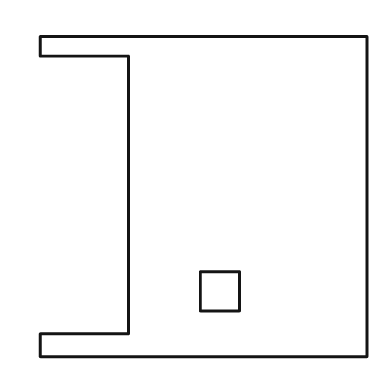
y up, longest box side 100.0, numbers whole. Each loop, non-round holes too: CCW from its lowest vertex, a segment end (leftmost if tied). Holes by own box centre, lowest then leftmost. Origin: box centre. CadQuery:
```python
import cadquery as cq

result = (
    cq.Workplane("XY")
    .moveTo(-50.0, -49.0)
    .lineTo(50.0, -49.0)
    .lineTo(50.0, 49.0)
    .lineTo(-50.0, 49.0)
    .lineTo(-50.0, 43.0)
    .lineTo(-23.0, 43.0)
    .lineTo(-23.0, -42.0)
    .lineTo(-50.0, -42.0)
    .close()
    .moveTo(-1.0, -35.0)
    .lineTo(11.0, -35.0)
    .lineTo(11.0, -23.0)
    .lineTo(-1.0, -23.0)
    .close()
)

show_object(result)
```